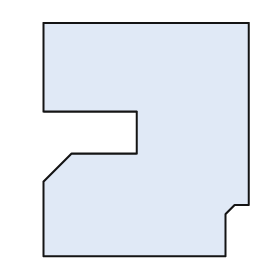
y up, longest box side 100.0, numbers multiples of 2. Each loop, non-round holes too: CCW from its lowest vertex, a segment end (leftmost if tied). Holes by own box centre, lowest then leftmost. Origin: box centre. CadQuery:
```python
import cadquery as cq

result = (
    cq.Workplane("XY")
    .moveTo(-44.0, -50.0)
    .lineTo(34.0, -50.0)
    .lineTo(34.0, -32.0)
    .lineTo(38.0, -28.0)
    .lineTo(44.0, -28.0)
    .lineTo(44.0, 50.0)
    .lineTo(-44.0, 50.0)
    .lineTo(-44.0, 12.0)
    .lineTo(-4.0, 12.0)
    .lineTo(-4.0, -6.0)
    .lineTo(-32.0, -6.0)
    .lineTo(-44.0, -18.0)
    .close()
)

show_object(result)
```